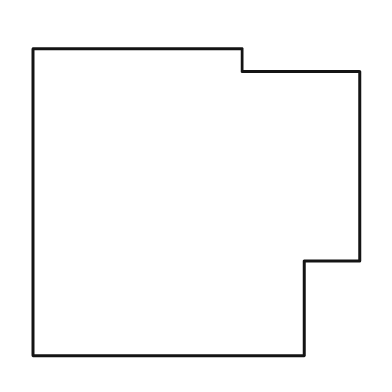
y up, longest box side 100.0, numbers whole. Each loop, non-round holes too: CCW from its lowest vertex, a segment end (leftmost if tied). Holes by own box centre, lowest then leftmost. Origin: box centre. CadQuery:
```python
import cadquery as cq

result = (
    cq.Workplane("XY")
    .moveTo(-50.0, -47.0)
    .lineTo(33.0, -47.0)
    .lineTo(33.0, -18.0)
    .lineTo(50.0, -18.0)
    .lineTo(50.0, 40.0)
    .lineTo(14.0, 40.0)
    .lineTo(14.0, 47.0)
    .lineTo(-50.0, 47.0)
    .close()
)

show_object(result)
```